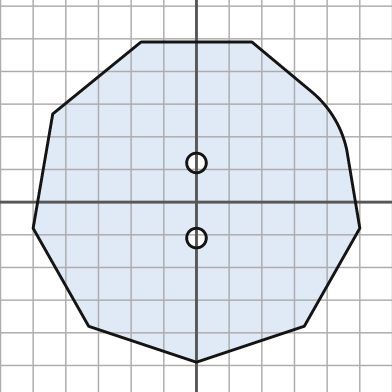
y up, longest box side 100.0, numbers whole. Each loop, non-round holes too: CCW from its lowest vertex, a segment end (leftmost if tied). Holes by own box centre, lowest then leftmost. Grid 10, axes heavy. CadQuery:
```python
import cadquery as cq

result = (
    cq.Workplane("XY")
    .moveTo(0.0, -49.0)
    .lineTo(33.0, -38.0)
    .lineTo(50.0, -8.0)
    .lineTo(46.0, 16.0)
    .threePointArc((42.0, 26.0), (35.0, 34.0))
    .lineTo(17.0, 49.0)
    .lineTo(-17.0, 49.0)
    .lineTo(-44.0, 27.0)
    .lineTo(-50.0, -8.0)
    .lineTo(-33.0, -38.0)
    .close()
    .moveTo(0.0, -11.0)
    .circle(3.0)
    .moveTo(0.0, 12.0)
    .circle(3.0)
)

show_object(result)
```